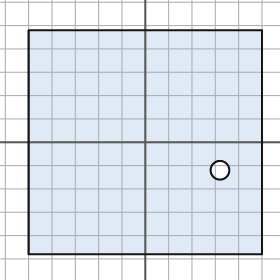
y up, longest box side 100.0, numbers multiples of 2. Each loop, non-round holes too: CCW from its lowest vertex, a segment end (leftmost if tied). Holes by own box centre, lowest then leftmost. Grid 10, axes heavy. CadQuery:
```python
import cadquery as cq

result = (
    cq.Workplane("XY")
    .moveTo(-50.0, -48.0)
    .lineTo(50.0, -48.0)
    .lineTo(50.0, 48.0)
    .lineTo(-50.0, 48.0)
    .close()
    .moveTo(32.0, -12.0)
    .circle(4.0)
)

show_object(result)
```